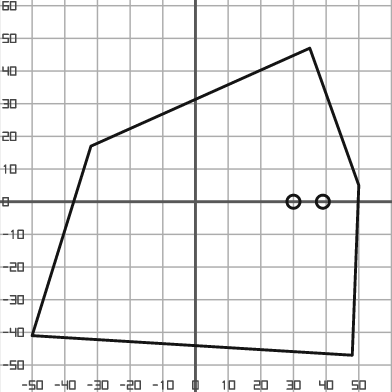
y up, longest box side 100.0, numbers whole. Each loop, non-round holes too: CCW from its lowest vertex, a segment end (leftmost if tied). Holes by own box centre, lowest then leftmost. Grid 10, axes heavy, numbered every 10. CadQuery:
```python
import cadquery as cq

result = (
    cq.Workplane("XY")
    .moveTo(48.0, -47.0)
    .lineTo(50.0, 5.0)
    .lineTo(35.0, 47.0)
    .lineTo(-32.0, 17.0)
    .lineTo(-50.0, -41.0)
    .close()
    .moveTo(30.0, 0.0)
    .circle(2.0)
    .moveTo(39.0, 0.0)
    .circle(2.0)
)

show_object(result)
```